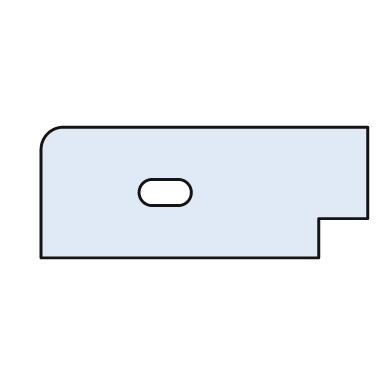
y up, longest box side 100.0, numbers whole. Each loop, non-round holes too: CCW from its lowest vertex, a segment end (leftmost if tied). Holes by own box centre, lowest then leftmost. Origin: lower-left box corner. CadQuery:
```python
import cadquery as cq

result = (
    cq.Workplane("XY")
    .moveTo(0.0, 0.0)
    .lineTo(85.0, 0.0)
    .lineTo(85.0, 12.0)
    .lineTo(100.0, 12.0)
    .lineTo(100.0, 40.0)
    .lineTo(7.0, 40.0)
    .threePointArc((2.0, 38.0), (0.0, 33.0))
    .close()
    .moveTo(34.0, 16.0)
    .lineTo(42.0, 16.0)
    .threePointArc((46.0, 20.0), (42.0, 24.0))
    .lineTo(34.0, 24.0)
    .threePointArc((30.0, 20.0), (34.0, 16.0))
    .close()
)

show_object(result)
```